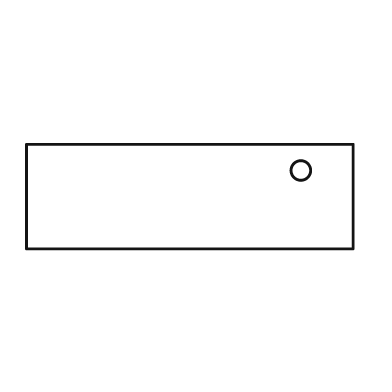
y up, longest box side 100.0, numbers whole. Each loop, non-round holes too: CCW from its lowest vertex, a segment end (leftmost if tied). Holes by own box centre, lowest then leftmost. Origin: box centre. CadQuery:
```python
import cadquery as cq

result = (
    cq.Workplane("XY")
    .moveTo(-50.0, -16.0)
    .lineTo(50.0, -16.0)
    .lineTo(50.0, 16.0)
    .lineTo(-50.0, 16.0)
    .close()
    .moveTo(34.0, 8.0)
    .circle(3.0)
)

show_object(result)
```